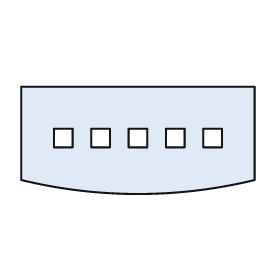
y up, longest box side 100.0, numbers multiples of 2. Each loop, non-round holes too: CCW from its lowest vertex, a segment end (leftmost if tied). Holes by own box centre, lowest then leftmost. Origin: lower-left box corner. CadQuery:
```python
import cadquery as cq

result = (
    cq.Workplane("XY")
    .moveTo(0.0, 6.0)
    .threePointArc((50.0, 0.0), (100.0, 6.0))
    .lineTo(100.0, 46.0)
    .lineTo(0.0, 46.0)
    .close()
    .moveTo(14.0, 20.0)
    .lineTo(22.0, 20.0)
    .lineTo(22.0, 28.0)
    .lineTo(14.0, 28.0)
    .close()
    .moveTo(30.0, 20.0)
    .lineTo(38.0, 20.0)
    .lineTo(38.0, 28.0)
    .lineTo(30.0, 28.0)
    .close()
    .moveTo(46.0, 20.0)
    .lineTo(54.0, 20.0)
    .lineTo(54.0, 28.0)
    .lineTo(46.0, 28.0)
    .close()
    .moveTo(62.0, 20.0)
    .lineTo(70.0, 20.0)
    .lineTo(70.0, 28.0)
    .lineTo(62.0, 28.0)
    .close()
    .moveTo(78.0, 20.0)
    .lineTo(86.0, 20.0)
    .lineTo(86.0, 28.0)
    .lineTo(78.0, 28.0)
    .close()
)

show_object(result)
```